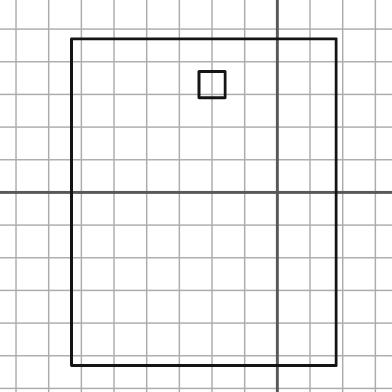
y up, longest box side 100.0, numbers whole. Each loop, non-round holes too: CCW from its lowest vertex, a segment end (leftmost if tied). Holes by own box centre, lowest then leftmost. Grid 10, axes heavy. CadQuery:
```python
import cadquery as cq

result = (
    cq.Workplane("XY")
    .moveTo(-63.0, -53.0)
    .lineTo(18.0, -53.0)
    .lineTo(18.0, 47.0)
    .lineTo(-63.0, 47.0)
    .close()
    .moveTo(-24.0, 29.0)
    .lineTo(-16.0, 29.0)
    .lineTo(-16.0, 37.0)
    .lineTo(-24.0, 37.0)
    .close()
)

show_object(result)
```